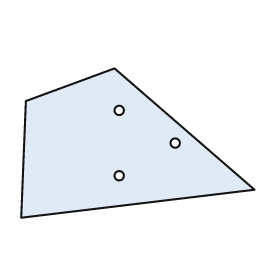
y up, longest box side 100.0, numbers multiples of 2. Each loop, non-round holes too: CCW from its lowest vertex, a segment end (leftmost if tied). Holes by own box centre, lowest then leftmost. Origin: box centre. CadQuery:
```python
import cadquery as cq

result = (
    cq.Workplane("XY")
    .moveTo(-50.0, -32.0)
    .lineTo(50.0, -20.0)
    .lineTo(-10.0, 32.0)
    .lineTo(-48.0, 18.0)
    .close()
    .moveTo(-8.0, -14.0)
    .circle(2.0)
    .moveTo(16.0, 0.0)
    .circle(2.0)
    .moveTo(-8.0, 14.0)
    .circle(2.0)
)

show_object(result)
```